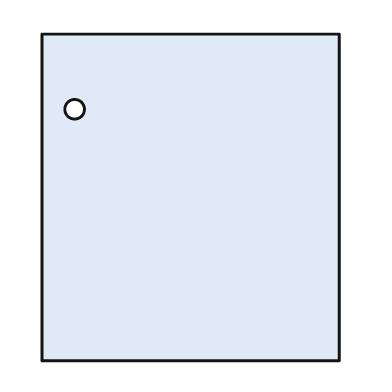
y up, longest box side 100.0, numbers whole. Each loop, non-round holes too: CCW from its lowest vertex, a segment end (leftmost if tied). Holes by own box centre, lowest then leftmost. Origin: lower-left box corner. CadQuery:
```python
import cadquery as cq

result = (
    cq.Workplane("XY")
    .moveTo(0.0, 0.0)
    .lineTo(91.0, 0.0)
    .lineTo(91.0, 100.0)
    .lineTo(0.0, 100.0)
    .close()
    .moveTo(10.0, 77.0)
    .circle(3.0)
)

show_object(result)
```